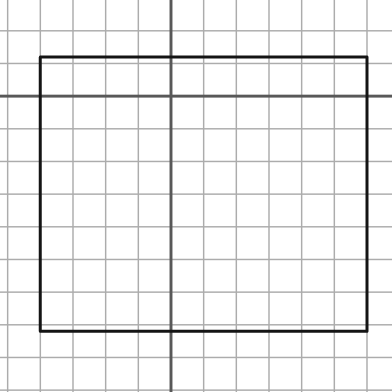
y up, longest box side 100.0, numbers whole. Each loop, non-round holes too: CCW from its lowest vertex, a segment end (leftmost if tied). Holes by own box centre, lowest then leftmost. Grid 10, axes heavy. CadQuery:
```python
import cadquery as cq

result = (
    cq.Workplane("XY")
    .moveTo(-40.0, -72.0)
    .lineTo(60.0, -72.0)
    .lineTo(60.0, 12.0)
    .lineTo(-40.0, 12.0)
    .close()
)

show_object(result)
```